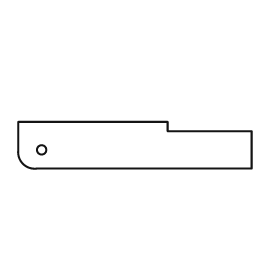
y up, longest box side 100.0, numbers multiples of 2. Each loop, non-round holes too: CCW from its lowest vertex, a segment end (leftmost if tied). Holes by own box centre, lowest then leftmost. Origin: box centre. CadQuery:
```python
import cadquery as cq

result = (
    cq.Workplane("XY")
    .moveTo(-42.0, -10.0)
    .lineTo(50.0, -10.0)
    .lineTo(50.0, 6.0)
    .lineTo(14.0, 6.0)
    .lineTo(14.0, 10.0)
    .lineTo(-50.0, 10.0)
    .lineTo(-50.0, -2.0)
    .threePointArc((-48.0, -8.0), (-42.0, -10.0))
    .close()
    .moveTo(-40.0, -2.0)
    .circle(2.0)
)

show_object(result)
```